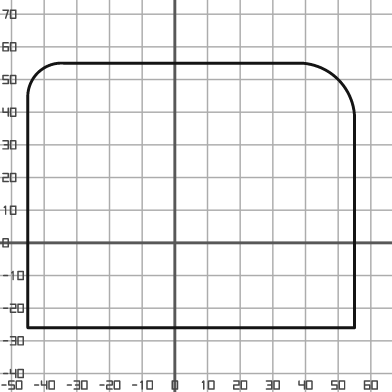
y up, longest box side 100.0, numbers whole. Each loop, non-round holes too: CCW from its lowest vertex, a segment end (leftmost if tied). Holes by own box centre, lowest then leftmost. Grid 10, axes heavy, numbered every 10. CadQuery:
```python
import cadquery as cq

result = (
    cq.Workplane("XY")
    .moveTo(-45.0, -26.0)
    .lineTo(55.0, -26.0)
    .lineTo(55.0, 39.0)
    .threePointArc((50.0, 50.0), (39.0, 55.0))
    .lineTo(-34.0, 55.0)
    .threePointArc((-42.0, 52.0), (-45.0, 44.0))
    .close()
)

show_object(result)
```